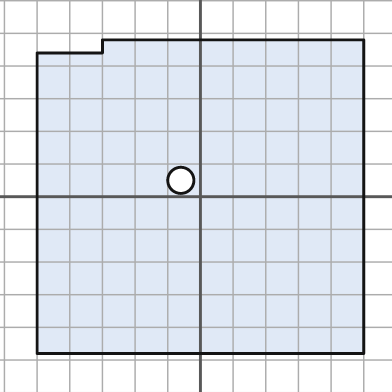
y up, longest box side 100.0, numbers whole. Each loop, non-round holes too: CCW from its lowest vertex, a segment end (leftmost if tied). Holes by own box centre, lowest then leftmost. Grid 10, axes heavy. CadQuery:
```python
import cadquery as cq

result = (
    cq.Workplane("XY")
    .moveTo(-50.0, -48.0)
    .lineTo(50.0, -48.0)
    .lineTo(50.0, 48.0)
    .lineTo(-30.0, 48.0)
    .lineTo(-30.0, 44.0)
    .lineTo(-50.0, 44.0)
    .close()
    .moveTo(-6.0, 5.0)
    .circle(4.0)
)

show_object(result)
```